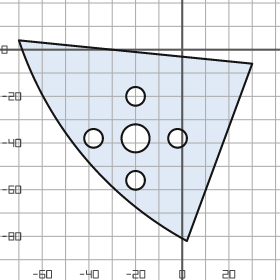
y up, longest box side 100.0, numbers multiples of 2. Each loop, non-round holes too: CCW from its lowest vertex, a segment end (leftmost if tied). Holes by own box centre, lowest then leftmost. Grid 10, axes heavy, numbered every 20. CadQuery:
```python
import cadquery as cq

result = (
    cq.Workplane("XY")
    .moveTo(2.0, -82.0)
    .lineTo(30.0, -6.0)
    .lineTo(-70.0, 4.0)
    .threePointArc((-42.0, -46.0), (2.0, -82.0))
    .close()
    .moveTo(-20.0, -56.0)
    .circle(4.0)
    .moveTo(-38.0, -38.0)
    .circle(4.0)
    .moveTo(-20.0, -38.0)
    .circle(6.0)
    .moveTo(-2.0, -38.0)
    .circle(4.0)
    .moveTo(-20.0, -20.0)
    .circle(4.0)
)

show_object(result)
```